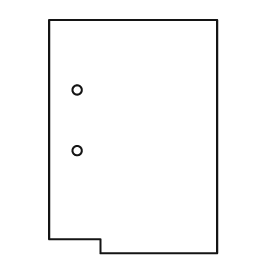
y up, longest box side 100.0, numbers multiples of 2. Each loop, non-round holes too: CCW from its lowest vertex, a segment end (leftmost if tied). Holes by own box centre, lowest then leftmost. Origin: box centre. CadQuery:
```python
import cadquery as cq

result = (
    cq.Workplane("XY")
    .moveTo(-14.0, -50.0)
    .lineTo(36.0, -50.0)
    .lineTo(36.0, 50.0)
    .lineTo(-36.0, 50.0)
    .lineTo(-36.0, -44.0)
    .lineTo(-14.0, -44.0)
    .close()
    .moveTo(-24.0, -6.0)
    .circle(2.0)
    .moveTo(-24.0, 20.0)
    .circle(2.0)
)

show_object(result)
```